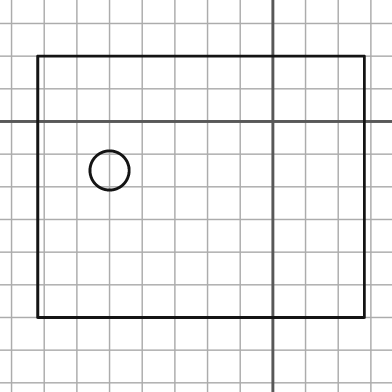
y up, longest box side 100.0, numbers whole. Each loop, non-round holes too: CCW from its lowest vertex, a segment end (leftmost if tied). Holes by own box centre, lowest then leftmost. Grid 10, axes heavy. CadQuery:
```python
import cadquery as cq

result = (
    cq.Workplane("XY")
    .moveTo(-72.0, -60.0)
    .lineTo(28.0, -60.0)
    .lineTo(28.0, 20.0)
    .lineTo(-72.0, 20.0)
    .close()
    .moveTo(-50.0, -15.0)
    .circle(6.0)
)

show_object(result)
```